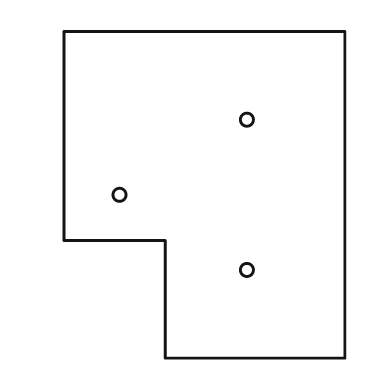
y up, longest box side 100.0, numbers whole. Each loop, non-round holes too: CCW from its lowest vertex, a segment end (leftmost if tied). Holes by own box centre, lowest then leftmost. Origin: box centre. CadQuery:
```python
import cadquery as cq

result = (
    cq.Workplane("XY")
    .moveTo(-12.0, -50.0)
    .lineTo(43.0, -50.0)
    .lineTo(43.0, 50.0)
    .lineTo(-43.0, 50.0)
    .lineTo(-43.0, -14.0)
    .lineTo(-12.0, -14.0)
    .close()
    .moveTo(13.0, -23.0)
    .circle(2.0)
    .moveTo(-26.0, 0.0)
    .circle(2.0)
    .moveTo(13.0, 23.0)
    .circle(2.0)
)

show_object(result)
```